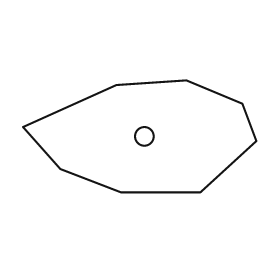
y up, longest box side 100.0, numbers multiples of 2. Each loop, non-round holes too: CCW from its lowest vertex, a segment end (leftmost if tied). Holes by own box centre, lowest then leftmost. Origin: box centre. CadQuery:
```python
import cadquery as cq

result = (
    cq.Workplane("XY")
    .moveTo(-8.0, -24.0)
    .lineTo(26.0, -24.0)
    .lineTo(50.0, -2.0)
    .lineTo(44.0, 14.0)
    .lineTo(20.0, 24.0)
    .lineTo(-10.0, 22.0)
    .lineTo(-50.0, 4.0)
    .lineTo(-34.0, -14.0)
    .close()
    .moveTo(2.0, 0.0)
    .circle(4.0)
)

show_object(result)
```